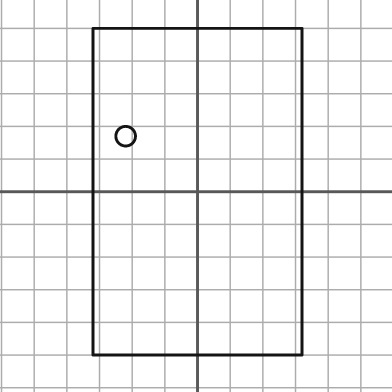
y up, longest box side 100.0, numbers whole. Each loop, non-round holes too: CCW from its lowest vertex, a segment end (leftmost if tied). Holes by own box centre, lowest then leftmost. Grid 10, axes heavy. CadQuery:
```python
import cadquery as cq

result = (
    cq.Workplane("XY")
    .moveTo(-32.0, -50.0)
    .lineTo(32.0, -50.0)
    .lineTo(32.0, 50.0)
    .lineTo(-32.0, 50.0)
    .close()
    .moveTo(-22.0, 17.0)
    .circle(3.0)
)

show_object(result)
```